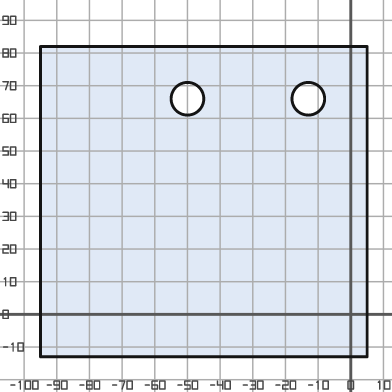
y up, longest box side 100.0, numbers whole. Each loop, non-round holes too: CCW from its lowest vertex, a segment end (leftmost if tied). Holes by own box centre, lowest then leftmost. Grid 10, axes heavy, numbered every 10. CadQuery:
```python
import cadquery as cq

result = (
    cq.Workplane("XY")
    .moveTo(-95.0, -13.0)
    .lineTo(5.0, -13.0)
    .lineTo(5.0, 82.0)
    .lineTo(-95.0, 82.0)
    .close()
    .moveTo(-50.0, 66.0)
    .circle(5.0)
    .moveTo(-13.0, 66.0)
    .circle(5.0)
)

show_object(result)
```